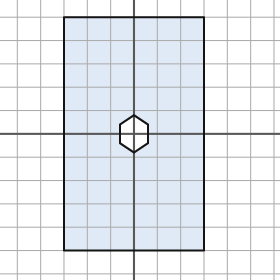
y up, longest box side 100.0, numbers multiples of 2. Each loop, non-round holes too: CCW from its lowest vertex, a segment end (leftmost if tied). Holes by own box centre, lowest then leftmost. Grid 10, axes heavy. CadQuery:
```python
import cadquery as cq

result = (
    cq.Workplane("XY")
    .moveTo(-30.0, -50.0)
    .lineTo(30.0, -50.0)
    .lineTo(30.0, 50.0)
    .lineTo(-30.0, 50.0)
    .close()
    .moveTo(0.0, -8.0)
    .lineTo(6.0, -4.0)
    .lineTo(6.0, 4.0)
    .lineTo(0.0, 8.0)
    .lineTo(-6.0, 4.0)
    .lineTo(-6.0, -4.0)
    .close()
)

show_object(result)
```